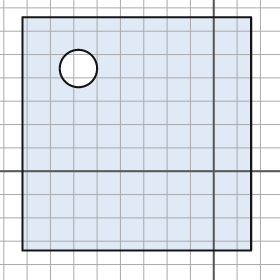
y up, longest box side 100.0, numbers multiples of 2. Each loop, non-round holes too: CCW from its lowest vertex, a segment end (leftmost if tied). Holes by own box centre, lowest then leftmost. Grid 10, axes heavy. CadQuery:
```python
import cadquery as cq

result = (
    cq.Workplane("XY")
    .moveTo(-82.0, -34.0)
    .lineTo(16.0, -34.0)
    .lineTo(16.0, 66.0)
    .lineTo(-82.0, 66.0)
    .close()
    .moveTo(-58.0, 44.0)
    .circle(8.0)
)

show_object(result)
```